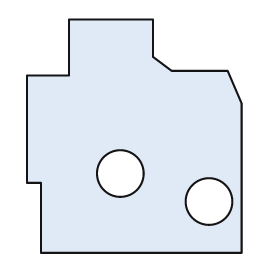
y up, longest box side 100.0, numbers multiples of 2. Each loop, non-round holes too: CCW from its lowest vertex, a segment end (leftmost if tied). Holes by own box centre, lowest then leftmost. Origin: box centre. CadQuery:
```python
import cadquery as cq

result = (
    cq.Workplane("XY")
    .moveTo(-40.0, -50.0)
    .lineTo(46.0, -50.0)
    .lineTo(46.0, 14.0)
    .lineTo(40.0, 28.0)
    .lineTo(16.0, 28.0)
    .lineTo(8.0, 34.0)
    .lineTo(8.0, 50.0)
    .lineTo(-28.0, 50.0)
    .lineTo(-28.0, 26.0)
    .lineTo(-46.0, 26.0)
    .lineTo(-46.0, -20.0)
    .lineTo(-40.0, -20.0)
    .close()
    .moveTo(32.0, -28.0)
    .circle(10.0)
    .moveTo(-6.0, -16.0)
    .circle(10.0)
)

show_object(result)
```